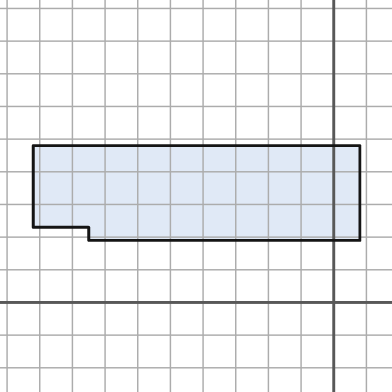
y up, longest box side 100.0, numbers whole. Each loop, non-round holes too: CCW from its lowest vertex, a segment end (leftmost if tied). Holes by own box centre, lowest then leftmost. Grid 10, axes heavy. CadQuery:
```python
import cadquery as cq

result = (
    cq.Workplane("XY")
    .moveTo(-75.0, 19.0)
    .lineTo(8.0, 19.0)
    .lineTo(8.0, 48.0)
    .lineTo(-92.0, 48.0)
    .lineTo(-92.0, 23.0)
    .lineTo(-75.0, 23.0)
    .close()
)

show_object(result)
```